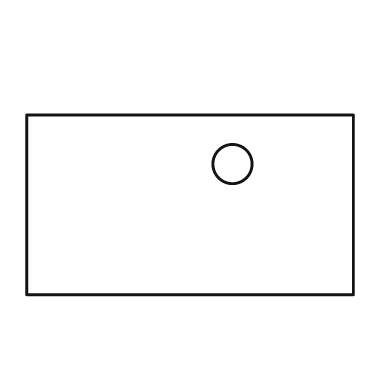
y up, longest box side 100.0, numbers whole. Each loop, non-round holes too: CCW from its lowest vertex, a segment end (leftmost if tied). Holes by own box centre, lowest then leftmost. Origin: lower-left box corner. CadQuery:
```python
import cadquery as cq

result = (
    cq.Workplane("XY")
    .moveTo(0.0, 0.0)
    .lineTo(100.0, 0.0)
    .lineTo(100.0, 55.0)
    .lineTo(0.0, 55.0)
    .close()
    .moveTo(63.0, 40.0)
    .circle(6.0)
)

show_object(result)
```